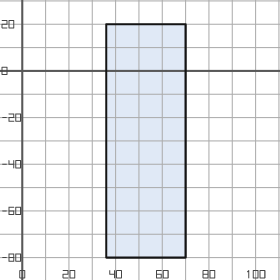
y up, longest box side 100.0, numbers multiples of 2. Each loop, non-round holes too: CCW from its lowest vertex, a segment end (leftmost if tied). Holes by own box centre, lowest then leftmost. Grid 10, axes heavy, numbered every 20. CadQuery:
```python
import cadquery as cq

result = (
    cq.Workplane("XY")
    .moveTo(36.0, -80.0)
    .lineTo(70.0, -80.0)
    .lineTo(70.0, 20.0)
    .lineTo(36.0, 20.0)
    .close()
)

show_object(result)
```